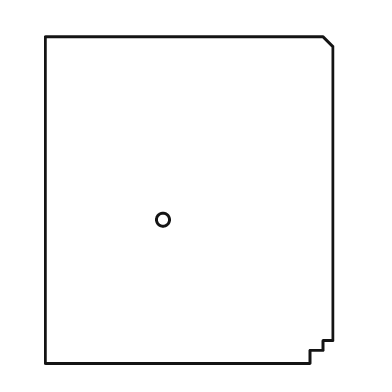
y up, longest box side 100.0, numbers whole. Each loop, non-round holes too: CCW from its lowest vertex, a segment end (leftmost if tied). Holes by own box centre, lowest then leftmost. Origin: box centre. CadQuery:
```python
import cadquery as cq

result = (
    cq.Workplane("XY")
    .moveTo(-44.0, -50.0)
    .lineTo(37.0, -50.0)
    .lineTo(37.0, -46.0)
    .lineTo(41.0, -46.0)
    .lineTo(41.0, -43.0)
    .lineTo(44.0, -43.0)
    .lineTo(44.0, 47.0)
    .lineTo(41.0, 50.0)
    .lineTo(-44.0, 50.0)
    .close()
    .moveTo(-8.0, -6.0)
    .circle(2.0)
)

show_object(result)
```